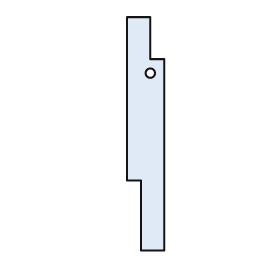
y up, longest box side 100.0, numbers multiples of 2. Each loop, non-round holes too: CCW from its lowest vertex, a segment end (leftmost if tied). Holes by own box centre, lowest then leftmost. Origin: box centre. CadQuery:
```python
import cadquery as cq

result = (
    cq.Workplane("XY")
    .moveTo(-2.0, -50.0)
    .lineTo(8.0, -50.0)
    .lineTo(8.0, 32.0)
    .lineTo(2.0, 32.0)
    .lineTo(2.0, 50.0)
    .lineTo(-8.0, 50.0)
    .lineTo(-8.0, -20.0)
    .lineTo(-2.0, -20.0)
    .close()
    .moveTo(2.0, 26.0)
    .circle(2.0)
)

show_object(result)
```